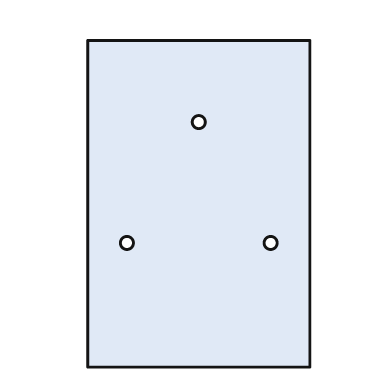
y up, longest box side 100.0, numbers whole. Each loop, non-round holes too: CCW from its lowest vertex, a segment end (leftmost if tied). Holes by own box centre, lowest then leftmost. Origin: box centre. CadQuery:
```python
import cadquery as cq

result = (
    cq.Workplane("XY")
    .moveTo(-34.0, -50.0)
    .lineTo(34.0, -50.0)
    .lineTo(34.0, 50.0)
    .lineTo(-34.0, 50.0)
    .close()
    .moveTo(-22.0, -12.0)
    .circle(2.0)
    .moveTo(22.0, -12.0)
    .circle(2.0)
    .moveTo(0.0, 25.0)
    .circle(2.0)
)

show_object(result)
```